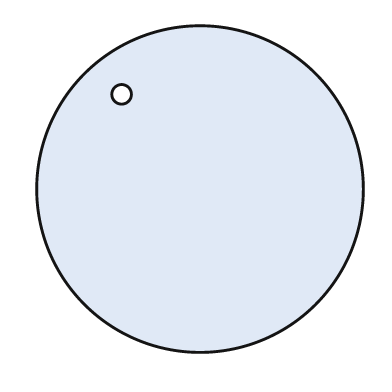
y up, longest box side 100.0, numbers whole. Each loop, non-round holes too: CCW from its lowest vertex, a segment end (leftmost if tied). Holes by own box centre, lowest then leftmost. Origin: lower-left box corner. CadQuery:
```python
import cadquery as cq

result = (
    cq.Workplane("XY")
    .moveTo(50.0, 50.0)
    .circle(50.0)
    .moveTo(26.0, 79.0)
    .circle(3.0)
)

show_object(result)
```